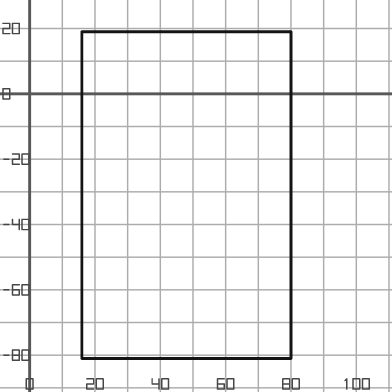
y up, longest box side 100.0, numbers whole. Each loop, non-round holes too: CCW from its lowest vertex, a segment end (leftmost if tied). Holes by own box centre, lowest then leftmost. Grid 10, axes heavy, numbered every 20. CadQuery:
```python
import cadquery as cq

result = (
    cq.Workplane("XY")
    .moveTo(16.0, -81.0)
    .lineTo(80.0, -81.0)
    .lineTo(80.0, 19.0)
    .lineTo(16.0, 19.0)
    .close()
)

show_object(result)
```